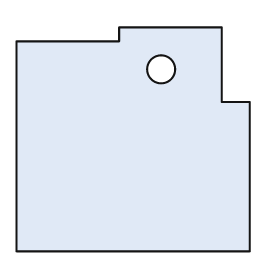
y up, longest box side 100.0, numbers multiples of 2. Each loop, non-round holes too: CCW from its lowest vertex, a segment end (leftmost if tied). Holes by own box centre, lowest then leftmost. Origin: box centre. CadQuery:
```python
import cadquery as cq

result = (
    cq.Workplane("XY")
    .moveTo(-50.0, -48.0)
    .lineTo(50.0, -48.0)
    .lineTo(50.0, 16.0)
    .lineTo(38.0, 16.0)
    .lineTo(38.0, 48.0)
    .lineTo(-6.0, 48.0)
    .lineTo(-6.0, 42.0)
    .lineTo(-50.0, 42.0)
    .close()
    .moveTo(12.0, 30.0)
    .circle(6.0)
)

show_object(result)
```